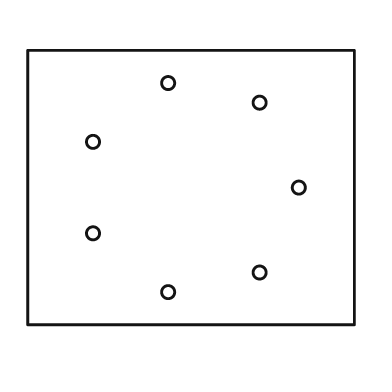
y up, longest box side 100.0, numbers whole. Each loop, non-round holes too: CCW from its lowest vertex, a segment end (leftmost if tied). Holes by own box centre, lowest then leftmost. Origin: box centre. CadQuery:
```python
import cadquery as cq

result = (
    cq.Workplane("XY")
    .moveTo(-50.0, -42.0)
    .lineTo(50.0, -42.0)
    .lineTo(50.0, 42.0)
    .lineTo(-50.0, 42.0)
    .close()
    .moveTo(-7.0, -32.0)
    .circle(2.0)
    .moveTo(21.0, -26.0)
    .circle(2.0)
    .moveTo(-30.0, -14.0)
    .circle(2.0)
    .moveTo(33.0, 0.0)
    .circle(2.0)
    .moveTo(-30.0, 14.0)
    .circle(2.0)
    .moveTo(21.0, 26.0)
    .circle(2.0)
    .moveTo(-7.0, 32.0)
    .circle(2.0)
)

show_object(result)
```